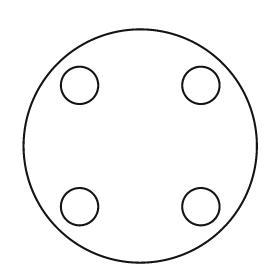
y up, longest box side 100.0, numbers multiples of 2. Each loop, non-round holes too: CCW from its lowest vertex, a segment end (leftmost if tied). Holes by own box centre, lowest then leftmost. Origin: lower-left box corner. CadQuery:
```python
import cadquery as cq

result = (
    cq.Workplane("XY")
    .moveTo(50.0, 50.0)
    .circle(50.0)
    .moveTo(24.0, 24.0)
    .circle(8.0)
    .moveTo(76.0, 24.0)
    .circle(8.0)
    .moveTo(24.0, 76.0)
    .circle(8.0)
    .moveTo(76.0, 76.0)
    .circle(8.0)
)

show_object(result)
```